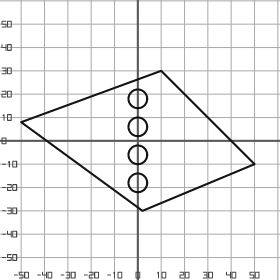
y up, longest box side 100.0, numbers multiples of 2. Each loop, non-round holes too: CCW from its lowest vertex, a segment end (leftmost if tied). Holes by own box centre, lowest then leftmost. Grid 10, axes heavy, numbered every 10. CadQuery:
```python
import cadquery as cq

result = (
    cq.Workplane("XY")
    .moveTo(2.0, -30.0)
    .lineTo(50.0, -10.0)
    .lineTo(10.0, 30.0)
    .lineTo(-50.0, 8.0)
    .close()
    .moveTo(0.0, -18.0)
    .circle(4.0)
    .moveTo(0.0, -6.0)
    .circle(4.0)
    .moveTo(0.0, 6.0)
    .circle(4.0)
    .moveTo(0.0, 18.0)
    .circle(4.0)
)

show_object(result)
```